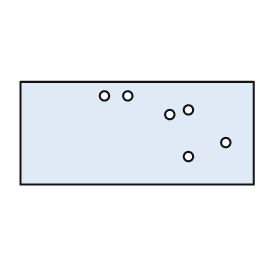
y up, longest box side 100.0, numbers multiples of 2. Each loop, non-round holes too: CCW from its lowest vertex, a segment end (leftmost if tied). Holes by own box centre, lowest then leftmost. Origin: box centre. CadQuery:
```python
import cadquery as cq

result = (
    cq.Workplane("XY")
    .moveTo(-50.0, -22.0)
    .lineTo(50.0, -22.0)
    .lineTo(50.0, 22.0)
    .lineTo(-50.0, 22.0)
    .close()
    .moveTo(22.0, -10.0)
    .circle(2.0)
    .moveTo(38.0, -4.0)
    .circle(2.0)
    .moveTo(14.0, 8.0)
    .circle(2.0)
    .moveTo(22.0, 10.0)
    .circle(2.0)
    .moveTo(-14.0, 16.0)
    .circle(2.0)
    .moveTo(-4.0, 16.0)
    .circle(2.0)
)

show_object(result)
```